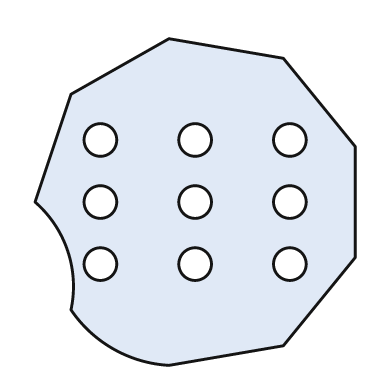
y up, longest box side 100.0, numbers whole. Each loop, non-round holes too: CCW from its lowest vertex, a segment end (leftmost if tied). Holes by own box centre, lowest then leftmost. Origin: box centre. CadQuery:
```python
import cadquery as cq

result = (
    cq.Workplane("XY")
    .moveTo(-8.0, -50.0)
    .lineTo(27.0, -44.0)
    .lineTo(49.0, -17.0)
    .lineTo(49.0, 17.0)
    .lineTo(27.0, 44.0)
    .lineTo(-8.0, 50.0)
    .lineTo(-38.0, 33.0)
    .lineTo(-49.0, 0.0)
    .threePointArc((-39.0, -15.0), (-38.0, -33.0))
    .threePointArc((-25.0, -45.0), (-8.0, -50.0))
    .close()
    .moveTo(-29.0, -19.0)
    .circle(5.0)
    .moveTo(0.0, -19.0)
    .circle(5.0)
    .moveTo(29.0, -19.0)
    .circle(5.0)
    .moveTo(-29.0, 0.0)
    .circle(5.0)
    .moveTo(0.0, 0.0)
    .circle(5.0)
    .moveTo(29.0, 0.0)
    .circle(5.0)
    .moveTo(-29.0, 19.0)
    .circle(5.0)
    .moveTo(0.0, 19.0)
    .circle(5.0)
    .moveTo(29.0, 19.0)
    .circle(5.0)
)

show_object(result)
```